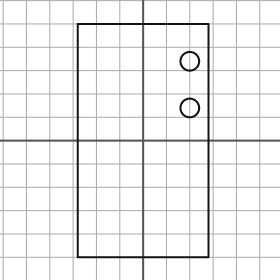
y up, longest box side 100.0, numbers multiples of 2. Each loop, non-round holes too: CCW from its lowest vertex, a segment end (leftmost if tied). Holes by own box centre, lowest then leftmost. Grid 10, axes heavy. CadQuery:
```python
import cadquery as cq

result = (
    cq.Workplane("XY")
    .moveTo(-28.0, -50.0)
    .lineTo(28.0, -50.0)
    .lineTo(28.0, 50.0)
    .lineTo(-28.0, 50.0)
    .close()
    .moveTo(20.0, 14.0)
    .circle(4.0)
    .moveTo(20.0, 34.0)
    .circle(4.0)
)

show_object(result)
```